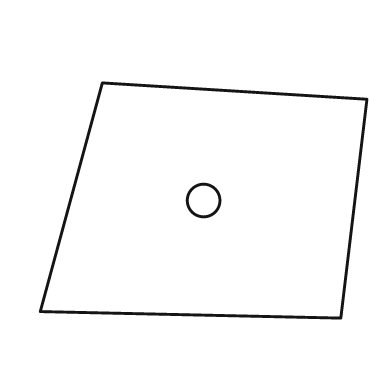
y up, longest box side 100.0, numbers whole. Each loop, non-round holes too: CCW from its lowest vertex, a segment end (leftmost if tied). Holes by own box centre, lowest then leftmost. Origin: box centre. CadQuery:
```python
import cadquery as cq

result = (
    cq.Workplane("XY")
    .moveTo(42.0, -36.0)
    .lineTo(50.0, 31.0)
    .lineTo(-31.0, 36.0)
    .lineTo(-50.0, -34.0)
    .close()
    .moveTo(0.0, 0.0)
    .circle(5.0)
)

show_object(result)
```